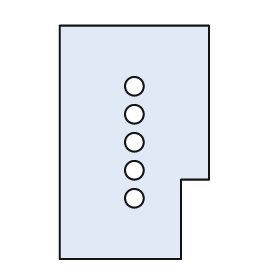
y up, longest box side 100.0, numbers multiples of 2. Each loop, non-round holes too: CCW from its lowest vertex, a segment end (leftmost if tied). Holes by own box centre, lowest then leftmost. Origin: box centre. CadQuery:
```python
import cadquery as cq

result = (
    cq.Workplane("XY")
    .moveTo(-32.0, -50.0)
    .lineTo(20.0, -50.0)
    .lineTo(20.0, -16.0)
    .lineTo(32.0, -16.0)
    .lineTo(32.0, 50.0)
    .lineTo(-32.0, 50.0)
    .close()
    .moveTo(0.0, -24.0)
    .circle(4.0)
    .moveTo(0.0, -12.0)
    .circle(4.0)
    .moveTo(0.0, 0.0)
    .circle(4.0)
    .moveTo(0.0, 12.0)
    .circle(4.0)
    .moveTo(0.0, 24.0)
    .circle(4.0)
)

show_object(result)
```